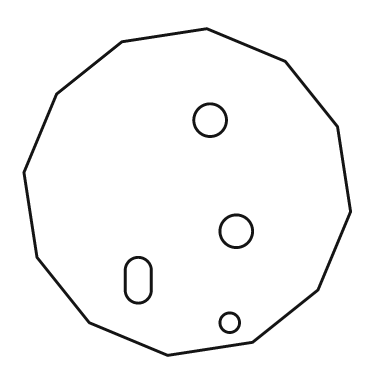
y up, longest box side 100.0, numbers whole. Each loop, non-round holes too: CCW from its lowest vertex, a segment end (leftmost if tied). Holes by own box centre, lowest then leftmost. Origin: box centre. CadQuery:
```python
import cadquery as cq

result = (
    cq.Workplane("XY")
    .moveTo(-6.0, -50.0)
    .lineTo(20.0, -46.0)
    .lineTo(40.0, -30.0)
    .lineTo(50.0, -6.0)
    .lineTo(46.0, 20.0)
    .lineTo(30.0, 40.0)
    .lineTo(6.0, 50.0)
    .lineTo(-20.0, 46.0)
    .lineTo(-40.0, 30.0)
    .lineTo(-50.0, 6.0)
    .lineTo(-46.0, -20.0)
    .lineTo(-30.0, -40.0)
    .close()
    .moveTo(13.0, -40.0)
    .circle(3.0)
    .moveTo(-19.0, -30.0)
    .threePointArc((-15.0, -34.0), (-11.0, -30.0))
    .lineTo(-11.0, -24.0)
    .threePointArc((-15.0, -20.0), (-19.0, -24.0))
    .close()
    .moveTo(15.0, -12.0)
    .circle(5.0)
    .moveTo(7.0, 22.0)
    .circle(5.0)
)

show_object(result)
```